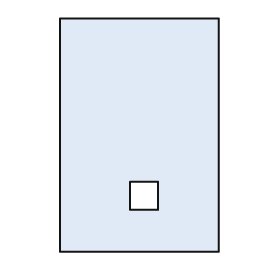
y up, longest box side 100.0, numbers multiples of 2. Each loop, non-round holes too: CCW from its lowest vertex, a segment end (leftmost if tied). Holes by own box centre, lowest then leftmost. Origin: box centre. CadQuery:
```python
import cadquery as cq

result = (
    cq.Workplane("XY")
    .moveTo(-34.0, -50.0)
    .lineTo(34.0, -50.0)
    .lineTo(34.0, 50.0)
    .lineTo(-34.0, 50.0)
    .close()
    .moveTo(-4.0, -32.0)
    .lineTo(8.0, -32.0)
    .lineTo(8.0, -20.0)
    .lineTo(-4.0, -20.0)
    .close()
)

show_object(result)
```